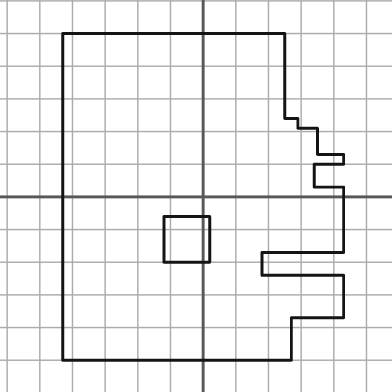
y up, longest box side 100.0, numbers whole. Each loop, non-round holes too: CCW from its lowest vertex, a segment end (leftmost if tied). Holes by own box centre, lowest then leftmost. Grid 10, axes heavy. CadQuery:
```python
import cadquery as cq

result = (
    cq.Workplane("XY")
    .moveTo(-43.0, -50.0)
    .lineTo(27.0, -50.0)
    .lineTo(27.0, -37.0)
    .lineTo(43.0, -37.0)
    .lineTo(43.0, -24.0)
    .lineTo(18.0, -24.0)
    .lineTo(18.0, -17.0)
    .lineTo(43.0, -17.0)
    .lineTo(43.0, 3.0)
    .lineTo(34.0, 3.0)
    .lineTo(34.0, 10.0)
    .lineTo(43.0, 10.0)
    .lineTo(43.0, 13.0)
    .lineTo(35.0, 13.0)
    .lineTo(35.0, 21.0)
    .lineTo(29.0, 21.0)
    .lineTo(29.0, 24.0)
    .lineTo(25.0, 24.0)
    .lineTo(25.0, 50.0)
    .lineTo(-43.0, 50.0)
    .close()
    .moveTo(-12.0, -20.0)
    .lineTo(2.0, -20.0)
    .lineTo(2.0, -6.0)
    .lineTo(-12.0, -6.0)
    .close()
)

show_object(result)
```